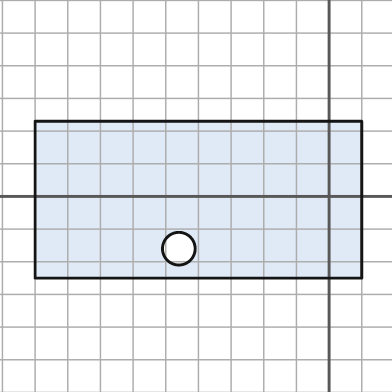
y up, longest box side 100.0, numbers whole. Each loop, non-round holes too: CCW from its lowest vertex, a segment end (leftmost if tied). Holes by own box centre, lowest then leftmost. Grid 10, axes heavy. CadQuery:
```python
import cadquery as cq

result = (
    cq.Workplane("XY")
    .moveTo(-90.0, -25.0)
    .lineTo(10.0, -25.0)
    .lineTo(10.0, 23.0)
    .lineTo(-90.0, 23.0)
    .close()
    .moveTo(-46.0, -16.0)
    .circle(5.0)
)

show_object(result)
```